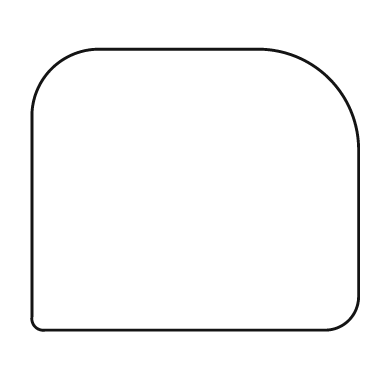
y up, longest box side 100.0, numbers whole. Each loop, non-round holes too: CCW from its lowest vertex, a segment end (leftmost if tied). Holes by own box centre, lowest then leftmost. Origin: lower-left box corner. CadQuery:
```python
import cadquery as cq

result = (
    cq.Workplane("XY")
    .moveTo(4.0, 0.0)
    .lineTo(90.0, 0.0)
    .threePointArc((97.0, 3.0), (100.0, 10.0))
    .lineTo(100.0, 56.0)
    .threePointArc((91.0, 77.0), (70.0, 86.0))
    .lineTo(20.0, 86.0)
    .threePointArc((6.0, 80.0), (0.0, 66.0))
    .lineTo(0.0, 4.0)
    .threePointArc((1.0, 1.0), (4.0, 0.0))
    .close()
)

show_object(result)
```